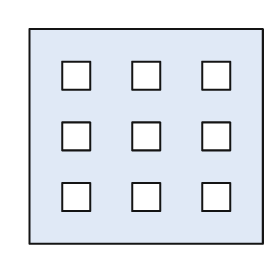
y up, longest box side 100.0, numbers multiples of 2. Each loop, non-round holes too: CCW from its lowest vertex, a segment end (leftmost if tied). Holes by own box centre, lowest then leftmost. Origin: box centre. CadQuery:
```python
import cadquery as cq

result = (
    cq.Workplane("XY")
    .moveTo(-50.0, -46.0)
    .lineTo(50.0, -46.0)
    .lineTo(50.0, 46.0)
    .lineTo(-50.0, 46.0)
    .close()
    .moveTo(-36.0, -32.0)
    .lineTo(-24.0, -32.0)
    .lineTo(-24.0, -20.0)
    .lineTo(-36.0, -20.0)
    .close()
    .moveTo(-6.0, -32.0)
    .lineTo(6.0, -32.0)
    .lineTo(6.0, -20.0)
    .lineTo(-6.0, -20.0)
    .close()
    .moveTo(24.0, -32.0)
    .lineTo(36.0, -32.0)
    .lineTo(36.0, -20.0)
    .lineTo(24.0, -20.0)
    .close()
    .moveTo(-36.0, -6.0)
    .lineTo(-24.0, -6.0)
    .lineTo(-24.0, 6.0)
    .lineTo(-36.0, 6.0)
    .close()
    .moveTo(-6.0, -6.0)
    .lineTo(6.0, -6.0)
    .lineTo(6.0, 6.0)
    .lineTo(-6.0, 6.0)
    .close()
    .moveTo(24.0, -6.0)
    .lineTo(36.0, -6.0)
    .lineTo(36.0, 6.0)
    .lineTo(24.0, 6.0)
    .close()
    .moveTo(-36.0, 20.0)
    .lineTo(-24.0, 20.0)
    .lineTo(-24.0, 32.0)
    .lineTo(-36.0, 32.0)
    .close()
    .moveTo(-6.0, 20.0)
    .lineTo(6.0, 20.0)
    .lineTo(6.0, 32.0)
    .lineTo(-6.0, 32.0)
    .close()
    .moveTo(24.0, 20.0)
    .lineTo(36.0, 20.0)
    .lineTo(36.0, 32.0)
    .lineTo(24.0, 32.0)
    .close()
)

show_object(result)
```